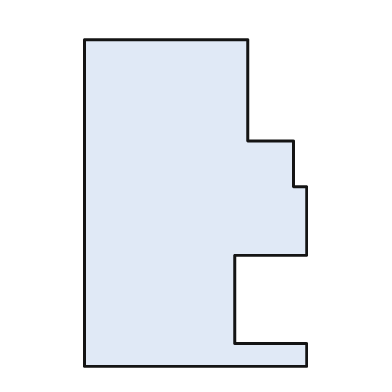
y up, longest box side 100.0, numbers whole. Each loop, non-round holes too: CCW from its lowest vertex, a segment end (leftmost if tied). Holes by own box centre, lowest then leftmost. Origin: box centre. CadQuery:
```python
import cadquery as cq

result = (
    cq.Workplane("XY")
    .moveTo(-34.0, -50.0)
    .lineTo(34.0, -50.0)
    .lineTo(34.0, -43.0)
    .lineTo(12.0, -43.0)
    .lineTo(12.0, -16.0)
    .lineTo(34.0, -16.0)
    .lineTo(34.0, 5.0)
    .lineTo(30.0, 5.0)
    .lineTo(30.0, 19.0)
    .lineTo(16.0, 19.0)
    .lineTo(16.0, 50.0)
    .lineTo(-34.0, 50.0)
    .close()
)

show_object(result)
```